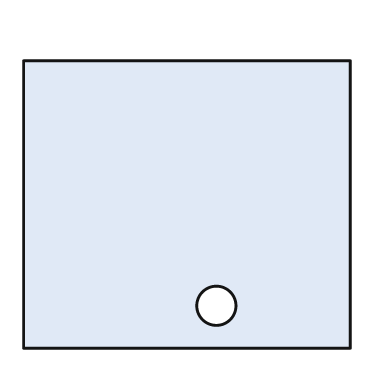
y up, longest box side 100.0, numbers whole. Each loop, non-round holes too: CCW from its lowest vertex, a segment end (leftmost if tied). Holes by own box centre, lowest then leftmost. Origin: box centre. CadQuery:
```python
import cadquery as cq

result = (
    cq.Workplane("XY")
    .moveTo(-50.0, -44.0)
    .lineTo(50.0, -44.0)
    .lineTo(50.0, 44.0)
    .lineTo(-50.0, 44.0)
    .close()
    .moveTo(9.0, -31.0)
    .circle(6.0)
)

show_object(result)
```